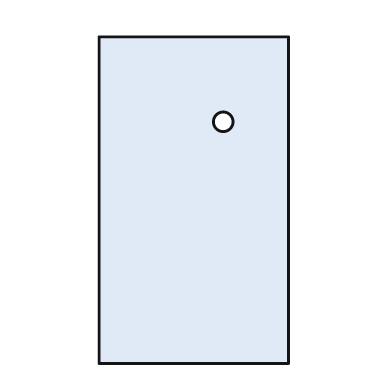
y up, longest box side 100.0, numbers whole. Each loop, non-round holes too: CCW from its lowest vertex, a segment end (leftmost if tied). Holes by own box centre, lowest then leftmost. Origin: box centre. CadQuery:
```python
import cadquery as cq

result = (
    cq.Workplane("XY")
    .moveTo(-29.0, -50.0)
    .lineTo(29.0, -50.0)
    .lineTo(29.0, 50.0)
    .lineTo(-29.0, 50.0)
    .close()
    .moveTo(9.0, 24.0)
    .circle(3.0)
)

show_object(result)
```